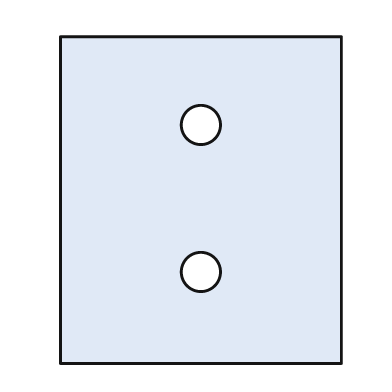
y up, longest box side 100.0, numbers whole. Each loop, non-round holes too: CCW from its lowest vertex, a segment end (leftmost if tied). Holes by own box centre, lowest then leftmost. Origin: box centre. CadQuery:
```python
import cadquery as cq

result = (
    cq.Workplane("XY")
    .moveTo(-43.0, -50.0)
    .lineTo(43.0, -50.0)
    .lineTo(43.0, 50.0)
    .lineTo(-43.0, 50.0)
    .close()
    .moveTo(0.0, -22.0)
    .circle(6.0)
    .moveTo(0.0, 23.0)
    .circle(6.0)
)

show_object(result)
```